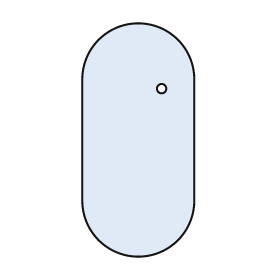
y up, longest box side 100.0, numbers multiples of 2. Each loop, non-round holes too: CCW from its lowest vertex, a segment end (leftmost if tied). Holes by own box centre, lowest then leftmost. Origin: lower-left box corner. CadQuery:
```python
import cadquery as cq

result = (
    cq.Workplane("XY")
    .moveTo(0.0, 24.0)
    .threePointArc((24.0, 0.0), (48.0, 24.0))
    .lineTo(48.0, 76.0)
    .threePointArc((24.0, 100.0), (0.0, 76.0))
    .close()
    .moveTo(34.0, 72.0)
    .circle(2.0)
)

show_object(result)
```